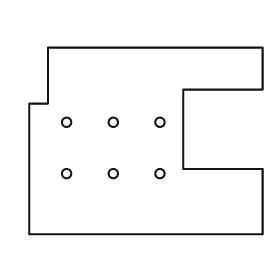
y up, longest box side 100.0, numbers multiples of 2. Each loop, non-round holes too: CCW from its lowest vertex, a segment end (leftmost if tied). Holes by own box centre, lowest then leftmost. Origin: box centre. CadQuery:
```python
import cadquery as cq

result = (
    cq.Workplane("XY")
    .moveTo(-50.0, -40.0)
    .lineTo(50.0, -40.0)
    .lineTo(50.0, -12.0)
    .lineTo(16.0, -12.0)
    .lineTo(16.0, 22.0)
    .lineTo(50.0, 22.0)
    .lineTo(50.0, 40.0)
    .lineTo(-42.0, 40.0)
    .lineTo(-42.0, 16.0)
    .lineTo(-50.0, 16.0)
    .close()
    .moveTo(-34.0, -14.0)
    .circle(2.0)
    .moveTo(-14.0, -14.0)
    .circle(2.0)
    .moveTo(6.0, -14.0)
    .circle(2.0)
    .moveTo(-34.0, 8.0)
    .circle(2.0)
    .moveTo(-14.0, 8.0)
    .circle(2.0)
    .moveTo(6.0, 8.0)
    .circle(2.0)
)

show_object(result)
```